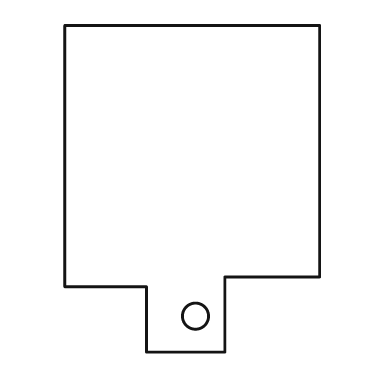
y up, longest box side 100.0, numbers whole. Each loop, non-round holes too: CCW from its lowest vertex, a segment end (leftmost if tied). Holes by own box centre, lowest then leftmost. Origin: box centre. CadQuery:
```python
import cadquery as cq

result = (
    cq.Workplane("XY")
    .moveTo(-14.0, -50.0)
    .lineTo(10.0, -50.0)
    .lineTo(10.0, -27.0)
    .lineTo(39.0, -27.0)
    .lineTo(39.0, 50.0)
    .lineTo(-39.0, 50.0)
    .lineTo(-39.0, -30.0)
    .lineTo(-14.0, -30.0)
    .close()
    .moveTo(1.0, -39.0)
    .circle(4.0)
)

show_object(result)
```